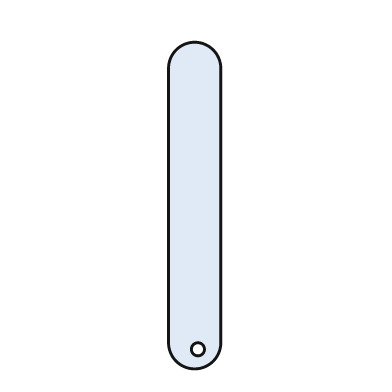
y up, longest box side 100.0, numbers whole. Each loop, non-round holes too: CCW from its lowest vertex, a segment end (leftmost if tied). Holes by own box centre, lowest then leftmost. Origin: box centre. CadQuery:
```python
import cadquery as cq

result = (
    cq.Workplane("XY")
    .moveTo(-8.0, -42.0)
    .threePointArc((0.0, -50.0), (8.0, -42.0))
    .lineTo(8.0, 42.0)
    .threePointArc((0.0, 50.0), (-8.0, 42.0))
    .close()
    .moveTo(1.0, -44.0)
    .circle(2.0)
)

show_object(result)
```